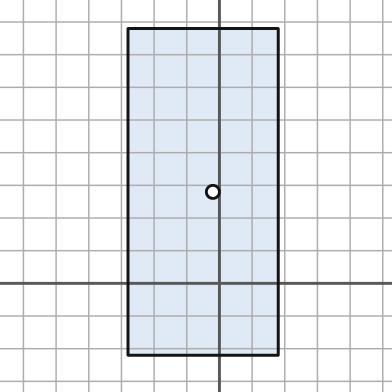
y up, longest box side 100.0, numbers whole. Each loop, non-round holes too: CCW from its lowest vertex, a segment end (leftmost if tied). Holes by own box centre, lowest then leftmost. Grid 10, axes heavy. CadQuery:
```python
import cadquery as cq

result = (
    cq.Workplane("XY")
    .moveTo(-28.0, -22.0)
    .lineTo(18.0, -22.0)
    .lineTo(18.0, 78.0)
    .lineTo(-28.0, 78.0)
    .close()
    .moveTo(-2.0, 28.0)
    .circle(2.0)
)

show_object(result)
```